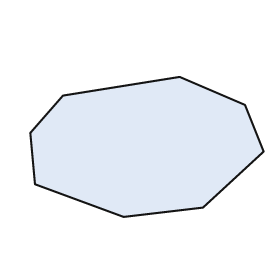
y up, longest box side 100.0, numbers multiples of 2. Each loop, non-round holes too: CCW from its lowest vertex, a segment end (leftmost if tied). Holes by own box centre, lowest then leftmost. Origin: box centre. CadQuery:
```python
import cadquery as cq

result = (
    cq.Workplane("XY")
    .moveTo(-10.0, -30.0)
    .lineTo(24.0, -26.0)
    .lineTo(50.0, -2.0)
    .lineTo(42.0, 18.0)
    .lineTo(14.0, 30.0)
    .lineTo(-36.0, 22.0)
    .lineTo(-50.0, 6.0)
    .lineTo(-48.0, -16.0)
    .close()
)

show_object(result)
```